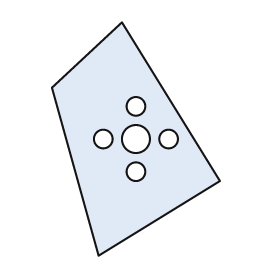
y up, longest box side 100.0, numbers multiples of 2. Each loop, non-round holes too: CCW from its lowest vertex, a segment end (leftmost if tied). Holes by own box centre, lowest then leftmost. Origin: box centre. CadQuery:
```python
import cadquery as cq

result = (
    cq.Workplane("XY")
    .moveTo(-16.0, -50.0)
    .lineTo(36.0, -18.0)
    .lineTo(-6.0, 50.0)
    .lineTo(-36.0, 22.0)
    .close()
    .moveTo(0.0, -14.0)
    .circle(4.0)
    .moveTo(-14.0, 0.0)
    .circle(4.0)
    .moveTo(0.0, 0.0)
    .circle(6.0)
    .moveTo(14.0, 0.0)
    .circle(4.0)
    .moveTo(0.0, 14.0)
    .circle(4.0)
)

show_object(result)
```